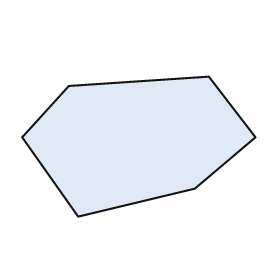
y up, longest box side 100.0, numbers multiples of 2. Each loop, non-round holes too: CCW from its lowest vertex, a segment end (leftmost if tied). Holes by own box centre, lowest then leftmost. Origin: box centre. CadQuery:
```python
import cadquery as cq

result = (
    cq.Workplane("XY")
    .moveTo(-26.0, -30.0)
    .lineTo(24.0, -18.0)
    .lineTo(50.0, 4.0)
    .lineTo(30.0, 30.0)
    .lineTo(-30.0, 26.0)
    .lineTo(-50.0, 4.0)
    .close()
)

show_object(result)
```